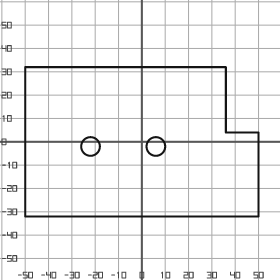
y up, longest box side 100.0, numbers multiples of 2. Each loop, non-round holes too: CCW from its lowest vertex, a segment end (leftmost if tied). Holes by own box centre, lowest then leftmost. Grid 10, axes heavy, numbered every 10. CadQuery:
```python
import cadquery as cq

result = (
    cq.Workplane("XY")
    .moveTo(-50.0, -32.0)
    .lineTo(50.0, -32.0)
    .lineTo(50.0, 4.0)
    .lineTo(36.0, 4.0)
    .lineTo(36.0, 32.0)
    .lineTo(-50.0, 32.0)
    .close()
    .moveTo(-22.0, -2.0)
    .circle(4.0)
    .moveTo(6.0, -2.0)
    .circle(4.0)
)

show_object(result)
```